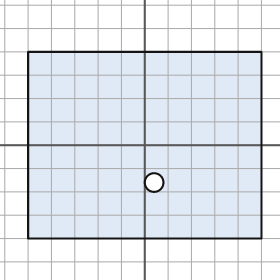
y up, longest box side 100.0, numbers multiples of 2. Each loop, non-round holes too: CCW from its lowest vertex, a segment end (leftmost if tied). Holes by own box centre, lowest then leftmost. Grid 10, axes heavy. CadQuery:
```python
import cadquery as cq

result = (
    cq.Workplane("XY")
    .moveTo(-50.0, -40.0)
    .lineTo(50.0, -40.0)
    .lineTo(50.0, 40.0)
    .lineTo(-50.0, 40.0)
    .close()
    .moveTo(4.0, -16.0)
    .circle(4.0)
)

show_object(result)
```